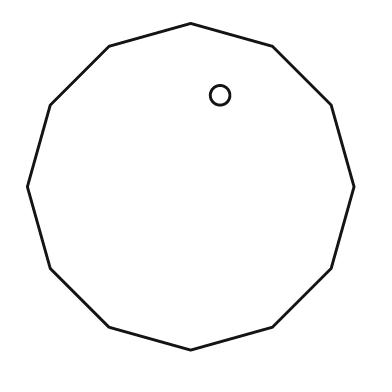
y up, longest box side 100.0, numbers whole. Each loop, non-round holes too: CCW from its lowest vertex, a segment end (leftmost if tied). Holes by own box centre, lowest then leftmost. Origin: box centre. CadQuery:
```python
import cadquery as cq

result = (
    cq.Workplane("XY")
    .moveTo(0.0, -50.0)
    .lineTo(25.0, -43.0)
    .lineTo(43.0, -25.0)
    .lineTo(50.0, 0.0)
    .lineTo(43.0, 25.0)
    .lineTo(25.0, 43.0)
    .lineTo(0.0, 50.0)
    .lineTo(-25.0, 43.0)
    .lineTo(-43.0, 25.0)
    .lineTo(-50.0, 0.0)
    .lineTo(-43.0, -25.0)
    .lineTo(-25.0, -43.0)
    .close()
    .moveTo(9.0, 28.0)
    .circle(3.0)
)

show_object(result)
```